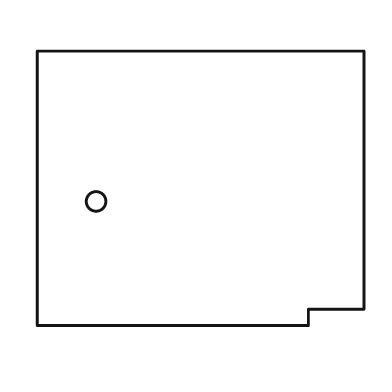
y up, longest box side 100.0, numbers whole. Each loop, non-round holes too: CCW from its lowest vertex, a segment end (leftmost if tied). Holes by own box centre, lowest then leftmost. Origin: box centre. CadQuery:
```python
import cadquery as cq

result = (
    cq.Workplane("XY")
    .moveTo(-50.0, -42.0)
    .lineTo(33.0, -42.0)
    .lineTo(33.0, -37.0)
    .lineTo(50.0, -37.0)
    .lineTo(50.0, 42.0)
    .lineTo(-50.0, 42.0)
    .close()
    .moveTo(-32.0, -4.0)
    .circle(3.0)
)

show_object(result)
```